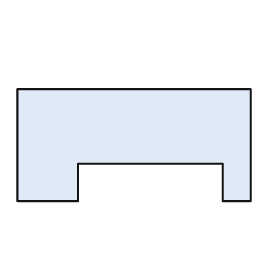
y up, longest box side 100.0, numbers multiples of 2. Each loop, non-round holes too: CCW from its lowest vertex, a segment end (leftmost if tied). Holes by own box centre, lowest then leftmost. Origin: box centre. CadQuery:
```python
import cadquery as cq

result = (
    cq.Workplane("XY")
    .moveTo(-50.0, -24.0)
    .lineTo(-24.0, -24.0)
    .lineTo(-24.0, -8.0)
    .lineTo(38.0, -8.0)
    .lineTo(38.0, -24.0)
    .lineTo(50.0, -24.0)
    .lineTo(50.0, 24.0)
    .lineTo(-50.0, 24.0)
    .close()
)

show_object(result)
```